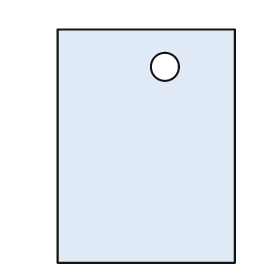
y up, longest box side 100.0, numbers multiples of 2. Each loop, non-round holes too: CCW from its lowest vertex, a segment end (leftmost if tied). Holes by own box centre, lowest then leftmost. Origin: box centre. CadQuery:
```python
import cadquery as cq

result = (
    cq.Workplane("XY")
    .moveTo(-38.0, -50.0)
    .lineTo(38.0, -50.0)
    .lineTo(38.0, 50.0)
    .lineTo(-38.0, 50.0)
    .close()
    .moveTo(8.0, 34.0)
    .circle(6.0)
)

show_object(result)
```